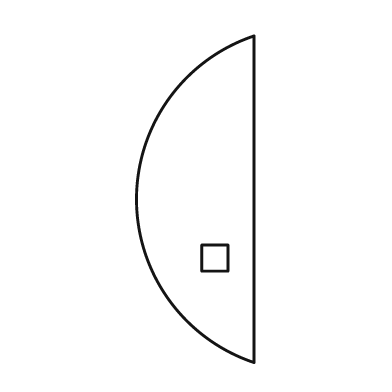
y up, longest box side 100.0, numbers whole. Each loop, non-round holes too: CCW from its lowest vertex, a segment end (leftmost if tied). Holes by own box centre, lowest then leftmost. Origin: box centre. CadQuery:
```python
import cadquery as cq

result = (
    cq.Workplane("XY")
    .moveTo(18.0, -50.0)
    .lineTo(18.0, 50.0)
    .threePointArc((-18.0, 0.0), (18.0, -50.0))
    .close()
    .moveTo(2.0, -22.0)
    .lineTo(10.0, -22.0)
    .lineTo(10.0, -14.0)
    .lineTo(2.0, -14.0)
    .close()
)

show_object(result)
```